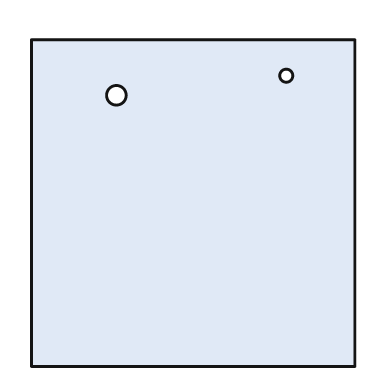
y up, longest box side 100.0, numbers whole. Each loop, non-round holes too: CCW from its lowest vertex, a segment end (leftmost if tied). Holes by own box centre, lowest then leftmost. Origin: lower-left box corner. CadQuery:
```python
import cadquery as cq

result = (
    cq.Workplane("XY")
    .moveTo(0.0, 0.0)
    .lineTo(99.0, 0.0)
    .lineTo(99.0, 100.0)
    .lineTo(0.0, 100.0)
    .close()
    .moveTo(26.0, 83.0)
    .circle(3.0)
    .moveTo(78.0, 89.0)
    .circle(2.0)
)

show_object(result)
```